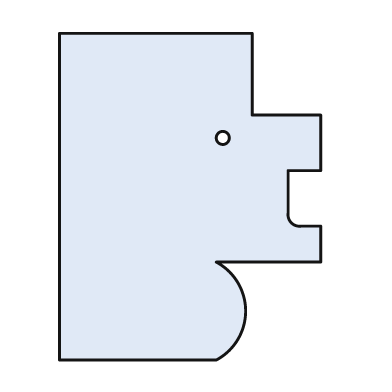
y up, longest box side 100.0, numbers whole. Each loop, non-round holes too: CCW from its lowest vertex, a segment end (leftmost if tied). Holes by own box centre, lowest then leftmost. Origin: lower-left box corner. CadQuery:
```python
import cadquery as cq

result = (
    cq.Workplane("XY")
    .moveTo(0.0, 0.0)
    .lineTo(48.0, 0.0)
    .threePointArc((57.0, 15.0), (48.0, 30.0))
    .lineTo(80.0, 30.0)
    .lineTo(80.0, 41.0)
    .lineTo(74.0, 41.0)
    .threePointArc((71.0, 42.0), (70.0, 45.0))
    .lineTo(70.0, 58.0)
    .lineTo(80.0, 58.0)
    .lineTo(80.0, 75.0)
    .lineTo(59.0, 75.0)
    .lineTo(59.0, 100.0)
    .lineTo(0.0, 100.0)
    .close()
    .moveTo(50.0, 68.0)
    .circle(2.0)
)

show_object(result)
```